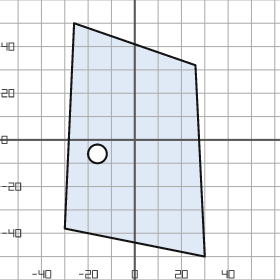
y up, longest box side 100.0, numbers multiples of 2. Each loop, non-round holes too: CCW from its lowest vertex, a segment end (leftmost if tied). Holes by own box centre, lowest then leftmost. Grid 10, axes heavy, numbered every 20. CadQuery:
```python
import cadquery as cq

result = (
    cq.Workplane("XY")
    .moveTo(30.0, -50.0)
    .lineTo(26.0, 32.0)
    .lineTo(-26.0, 50.0)
    .lineTo(-30.0, -38.0)
    .close()
    .moveTo(-16.0, -6.0)
    .circle(4.0)
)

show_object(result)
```